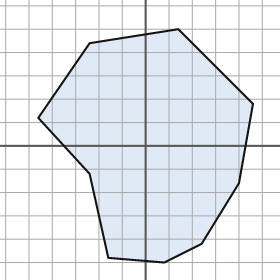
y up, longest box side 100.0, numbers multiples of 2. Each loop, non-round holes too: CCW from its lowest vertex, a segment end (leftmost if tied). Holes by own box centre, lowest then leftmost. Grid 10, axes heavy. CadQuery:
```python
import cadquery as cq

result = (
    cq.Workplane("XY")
    .moveTo(8.0, -50.0)
    .lineTo(24.0, -42.0)
    .lineTo(40.0, -16.0)
    .lineTo(46.0, 18.0)
    .lineTo(14.0, 50.0)
    .lineTo(-24.0, 44.0)
    .lineTo(-46.0, 12.0)
    .lineTo(-24.0, -12.0)
    .lineTo(-16.0, -48.0)
    .close()
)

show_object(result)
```